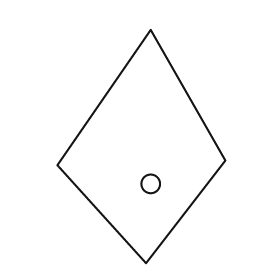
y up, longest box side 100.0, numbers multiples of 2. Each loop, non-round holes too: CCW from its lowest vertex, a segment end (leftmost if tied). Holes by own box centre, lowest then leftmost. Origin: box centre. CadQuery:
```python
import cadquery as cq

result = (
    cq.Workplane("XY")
    .moveTo(2.0, -50.0)
    .lineTo(36.0, -6.0)
    .lineTo(4.0, 50.0)
    .lineTo(-36.0, -8.0)
    .close()
    .moveTo(4.0, -16.0)
    .circle(4.0)
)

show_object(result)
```